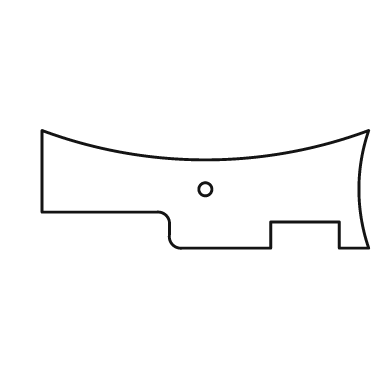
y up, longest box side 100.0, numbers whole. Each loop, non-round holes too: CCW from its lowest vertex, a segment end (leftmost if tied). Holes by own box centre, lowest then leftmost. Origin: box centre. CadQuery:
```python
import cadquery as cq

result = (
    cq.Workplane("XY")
    .moveTo(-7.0, -18.0)
    .lineTo(20.0, -18.0)
    .lineTo(20.0, -10.0)
    .lineTo(41.0, -10.0)
    .lineTo(41.0, -18.0)
    .lineTo(50.0, -18.0)
    .threePointArc((47.0, 0.0), (50.0, 18.0))
    .threePointArc((0.0, 9.0), (-50.0, 18.0))
    .lineTo(-50.0, -7.0)
    .lineTo(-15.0, -7.0)
    .threePointArc((-12.0, -8.0), (-11.0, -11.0))
    .lineTo(-11.0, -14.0)
    .threePointArc((-10.0, -17.0), (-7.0, -18.0))
    .close()
    .moveTo(0.0, 0.0)
    .circle(2.0)
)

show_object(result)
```